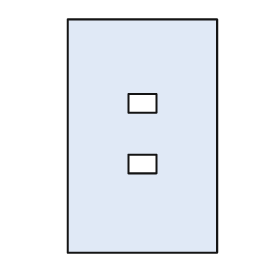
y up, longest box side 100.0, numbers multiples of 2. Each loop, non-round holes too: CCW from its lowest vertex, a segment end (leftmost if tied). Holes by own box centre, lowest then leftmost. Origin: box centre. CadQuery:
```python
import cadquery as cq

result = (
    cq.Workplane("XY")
    .moveTo(-32.0, -50.0)
    .lineTo(32.0, -50.0)
    .lineTo(32.0, 50.0)
    .lineTo(-32.0, 50.0)
    .close()
    .moveTo(-6.0, -16.0)
    .lineTo(6.0, -16.0)
    .lineTo(6.0, -8.0)
    .lineTo(-6.0, -8.0)
    .close()
    .moveTo(-6.0, 10.0)
    .lineTo(6.0, 10.0)
    .lineTo(6.0, 18.0)
    .lineTo(-6.0, 18.0)
    .close()
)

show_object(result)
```